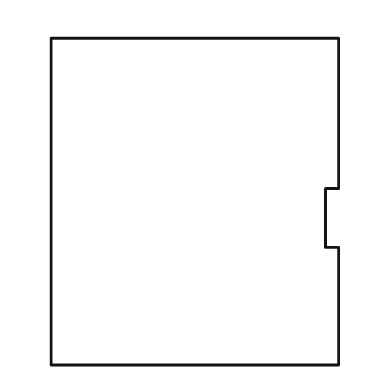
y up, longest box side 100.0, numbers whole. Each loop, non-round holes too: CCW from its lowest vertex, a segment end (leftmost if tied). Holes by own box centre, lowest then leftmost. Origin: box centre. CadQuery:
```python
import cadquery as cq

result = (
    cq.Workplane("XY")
    .moveTo(-44.0, -50.0)
    .lineTo(44.0, -50.0)
    .lineTo(44.0, -14.0)
    .lineTo(40.0, -14.0)
    .lineTo(40.0, 4.0)
    .lineTo(44.0, 4.0)
    .lineTo(44.0, 50.0)
    .lineTo(-44.0, 50.0)
    .close()
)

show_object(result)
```